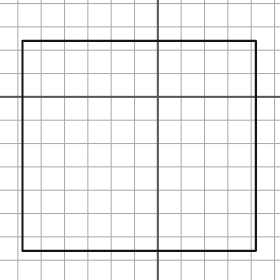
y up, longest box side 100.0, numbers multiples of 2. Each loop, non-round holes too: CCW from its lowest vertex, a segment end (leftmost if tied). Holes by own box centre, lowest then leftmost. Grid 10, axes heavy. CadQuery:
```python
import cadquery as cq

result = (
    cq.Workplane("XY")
    .moveTo(-58.0, -66.0)
    .lineTo(42.0, -66.0)
    .lineTo(42.0, 24.0)
    .lineTo(-58.0, 24.0)
    .close()
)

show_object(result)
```